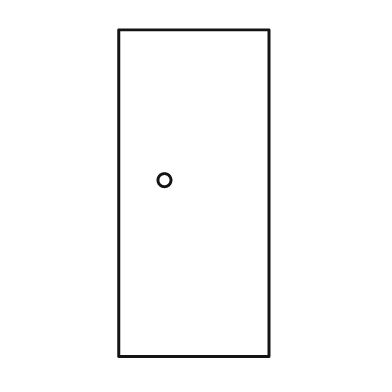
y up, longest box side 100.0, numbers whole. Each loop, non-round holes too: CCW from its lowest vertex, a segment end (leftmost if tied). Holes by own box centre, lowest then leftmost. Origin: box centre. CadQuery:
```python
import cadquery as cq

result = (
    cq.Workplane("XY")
    .moveTo(-23.0, -50.0)
    .lineTo(23.0, -50.0)
    .lineTo(23.0, 50.0)
    .lineTo(-23.0, 50.0)
    .close()
    .moveTo(-9.0, 4.0)
    .circle(2.0)
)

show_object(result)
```